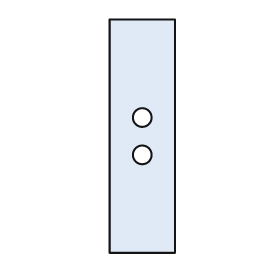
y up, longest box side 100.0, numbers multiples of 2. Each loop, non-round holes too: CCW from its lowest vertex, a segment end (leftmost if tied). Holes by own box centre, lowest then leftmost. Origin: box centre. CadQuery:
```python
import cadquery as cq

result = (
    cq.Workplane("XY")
    .moveTo(-14.0, -50.0)
    .lineTo(14.0, -50.0)
    .lineTo(14.0, 50.0)
    .lineTo(-14.0, 50.0)
    .close()
    .moveTo(0.0, -8.0)
    .circle(4.0)
    .moveTo(0.0, 8.0)
    .circle(4.0)
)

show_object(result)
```